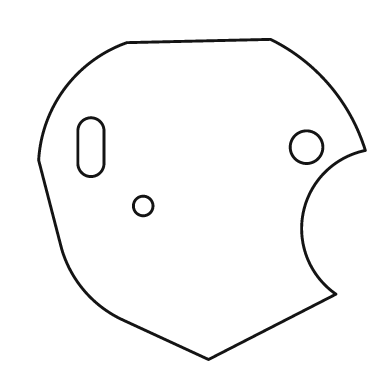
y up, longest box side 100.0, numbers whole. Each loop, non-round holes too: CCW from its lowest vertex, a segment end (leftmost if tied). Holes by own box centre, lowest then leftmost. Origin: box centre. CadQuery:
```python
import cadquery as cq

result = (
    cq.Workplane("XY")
    .moveTo(2.0, -49.0)
    .lineTo(41.0, -29.0)
    .threePointArc((31.0, -4.0), (50.0, 15.0))
    .threePointArc((39.0, 35.0), (21.0, 49.0))
    .lineTo(-23.0, 48.0)
    .threePointArc((-42.0, 34.0), (-50.0, 12.0))
    .lineTo(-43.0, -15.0)
    .threePointArc((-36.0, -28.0), (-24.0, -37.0))
    .close()
    .moveTo(-18.0, -2.0)
    .circle(3.0)
    .moveTo(-38.0, 11.0)
    .threePointArc((-34.0, 7.0), (-30.0, 11.0))
    .lineTo(-30.0, 21.0)
    .threePointArc((-34.0, 25.0), (-38.0, 21.0))
    .close()
    .moveTo(32.0, 16.0)
    .circle(5.0)
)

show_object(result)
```